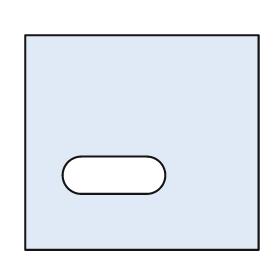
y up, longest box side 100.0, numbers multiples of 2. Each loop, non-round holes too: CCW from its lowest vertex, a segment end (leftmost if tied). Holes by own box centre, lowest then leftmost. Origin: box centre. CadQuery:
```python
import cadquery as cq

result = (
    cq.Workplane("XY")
    .moveTo(-50.0, -46.0)
    .lineTo(50.0, -46.0)
    .lineTo(50.0, 46.0)
    .lineTo(-50.0, 46.0)
    .close()
    .moveTo(-26.0, -22.0)
    .lineTo(2.0, -22.0)
    .threePointArc((10.0, -14.0), (2.0, -6.0))
    .lineTo(-26.0, -6.0)
    .threePointArc((-34.0, -14.0), (-26.0, -22.0))
    .close()
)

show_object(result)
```